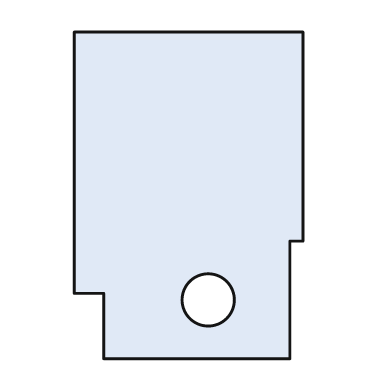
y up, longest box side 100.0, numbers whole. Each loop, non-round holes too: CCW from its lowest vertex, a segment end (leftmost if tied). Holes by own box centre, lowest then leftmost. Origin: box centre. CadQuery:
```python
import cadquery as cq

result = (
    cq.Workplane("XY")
    .moveTo(-26.0, -50.0)
    .lineTo(31.0, -50.0)
    .lineTo(31.0, -14.0)
    .lineTo(35.0, -14.0)
    .lineTo(35.0, 50.0)
    .lineTo(-35.0, 50.0)
    .lineTo(-35.0, -30.0)
    .lineTo(-26.0, -30.0)
    .close()
    .moveTo(6.0, -32.0)
    .circle(8.0)
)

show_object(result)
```